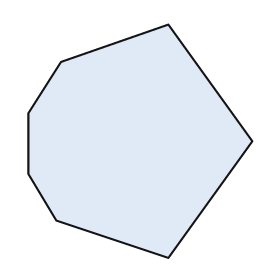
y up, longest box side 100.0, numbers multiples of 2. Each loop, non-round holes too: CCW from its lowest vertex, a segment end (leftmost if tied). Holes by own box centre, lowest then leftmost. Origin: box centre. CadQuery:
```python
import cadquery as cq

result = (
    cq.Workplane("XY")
    .moveTo(12.0, -50.0)
    .lineTo(48.0, 0.0)
    .lineTo(12.0, 50.0)
    .lineTo(-34.0, 34.0)
    .lineTo(-48.0, 12.0)
    .lineTo(-48.0, -14.0)
    .lineTo(-36.0, -34.0)
    .close()
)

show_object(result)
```